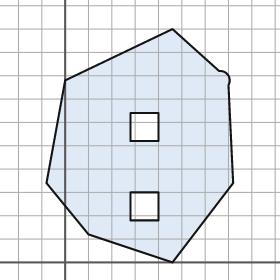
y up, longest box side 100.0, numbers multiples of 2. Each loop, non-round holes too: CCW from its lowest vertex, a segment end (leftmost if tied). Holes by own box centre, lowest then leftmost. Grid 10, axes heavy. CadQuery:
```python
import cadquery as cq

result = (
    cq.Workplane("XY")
    .moveTo(46.0, 0.0)
    .lineTo(72.0, 34.0)
    .lineTo(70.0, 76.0)
    .threePointArc((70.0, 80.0), (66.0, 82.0))
    .lineTo(46.0, 100.0)
    .lineTo(0.0, 78.0)
    .lineTo(-8.0, 34.0)
    .lineTo(10.0, 12.0)
    .close()
    .moveTo(28.0, 18.0)
    .lineTo(40.0, 18.0)
    .lineTo(40.0, 30.0)
    .lineTo(28.0, 30.0)
    .close()
    .moveTo(28.0, 52.0)
    .lineTo(40.0, 52.0)
    .lineTo(40.0, 64.0)
    .lineTo(28.0, 64.0)
    .close()
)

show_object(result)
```